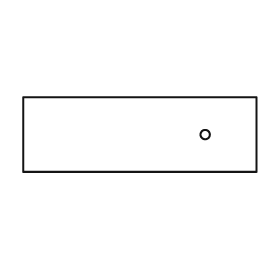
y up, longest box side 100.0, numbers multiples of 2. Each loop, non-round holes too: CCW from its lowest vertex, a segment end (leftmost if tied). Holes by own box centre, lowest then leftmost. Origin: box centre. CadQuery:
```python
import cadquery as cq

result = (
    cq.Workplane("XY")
    .moveTo(-50.0, -16.0)
    .lineTo(50.0, -16.0)
    .lineTo(50.0, 16.0)
    .lineTo(-50.0, 16.0)
    .close()
    .moveTo(28.0, 0.0)
    .circle(2.0)
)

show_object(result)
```